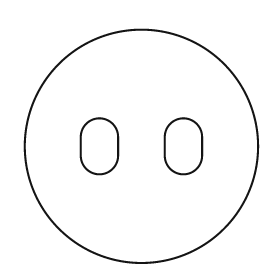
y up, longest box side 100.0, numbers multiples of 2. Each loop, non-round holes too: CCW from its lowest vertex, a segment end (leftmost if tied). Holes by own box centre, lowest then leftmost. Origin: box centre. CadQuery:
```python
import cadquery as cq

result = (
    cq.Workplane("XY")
    .moveTo(0.0, 0.0)
    .circle(50.0)
    .moveTo(-26.0, -4.0)
    .threePointArc((-18.0, -12.0), (-10.0, -4.0))
    .lineTo(-10.0, 4.0)
    .threePointArc((-18.0, 12.0), (-26.0, 4.0))
    .close()
    .moveTo(10.0, -4.0)
    .threePointArc((18.0, -12.0), (26.0, -4.0))
    .lineTo(26.0, 4.0)
    .threePointArc((18.0, 12.0), (10.0, 4.0))
    .close()
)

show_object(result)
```